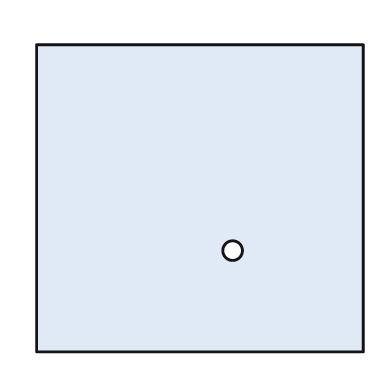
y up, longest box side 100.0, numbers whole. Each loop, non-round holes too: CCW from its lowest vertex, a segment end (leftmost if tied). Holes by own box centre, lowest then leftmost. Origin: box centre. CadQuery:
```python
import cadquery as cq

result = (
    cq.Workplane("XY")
    .moveTo(-50.0, -47.0)
    .lineTo(50.0, -47.0)
    .lineTo(50.0, 47.0)
    .lineTo(-50.0, 47.0)
    .close()
    .moveTo(10.0, -16.0)
    .circle(3.0)
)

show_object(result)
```